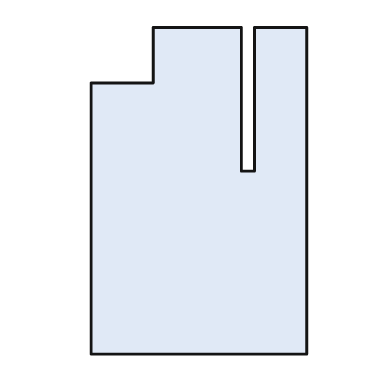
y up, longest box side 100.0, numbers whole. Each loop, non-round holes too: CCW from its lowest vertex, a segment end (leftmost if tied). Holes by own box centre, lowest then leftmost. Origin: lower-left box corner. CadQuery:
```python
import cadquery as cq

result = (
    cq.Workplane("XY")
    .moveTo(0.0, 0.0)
    .lineTo(66.0, 0.0)
    .lineTo(66.0, 100.0)
    .lineTo(50.0, 100.0)
    .lineTo(50.0, 56.0)
    .lineTo(46.0, 56.0)
    .lineTo(46.0, 100.0)
    .lineTo(19.0, 100.0)
    .lineTo(19.0, 83.0)
    .lineTo(0.0, 83.0)
    .close()
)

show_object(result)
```